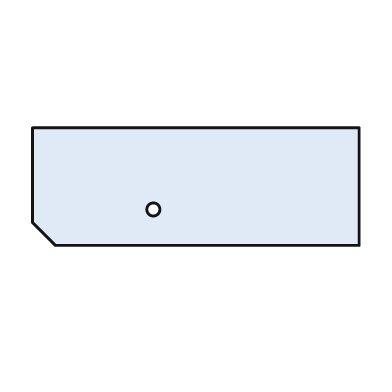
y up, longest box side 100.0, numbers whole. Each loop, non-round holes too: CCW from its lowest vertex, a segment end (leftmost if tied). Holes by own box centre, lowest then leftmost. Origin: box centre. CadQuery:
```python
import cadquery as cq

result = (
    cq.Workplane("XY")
    .moveTo(-43.0, -18.0)
    .lineTo(50.0, -18.0)
    .lineTo(50.0, 18.0)
    .lineTo(-50.0, 18.0)
    .lineTo(-50.0, -11.0)
    .close()
    .moveTo(-13.0, -7.0)
    .circle(2.0)
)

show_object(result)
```